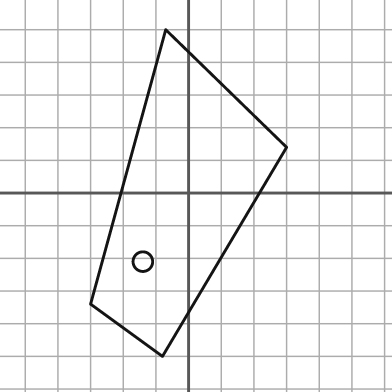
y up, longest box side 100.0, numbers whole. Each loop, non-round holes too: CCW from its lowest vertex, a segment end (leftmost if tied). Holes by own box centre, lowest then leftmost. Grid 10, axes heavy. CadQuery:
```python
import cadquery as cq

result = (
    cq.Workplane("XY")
    .moveTo(-8.0, -50.0)
    .lineTo(30.0, 14.0)
    .lineTo(-7.0, 50.0)
    .lineTo(-30.0, -34.0)
    .close()
    .moveTo(-14.0, -21.0)
    .circle(3.0)
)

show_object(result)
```